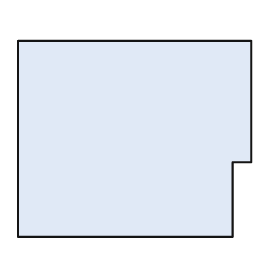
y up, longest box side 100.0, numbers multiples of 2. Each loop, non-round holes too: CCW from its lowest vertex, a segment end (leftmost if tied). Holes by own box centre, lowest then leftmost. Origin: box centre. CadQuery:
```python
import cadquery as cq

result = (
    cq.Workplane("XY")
    .moveTo(-50.0, -42.0)
    .lineTo(42.0, -42.0)
    .lineTo(42.0, -10.0)
    .lineTo(50.0, -10.0)
    .lineTo(50.0, 42.0)
    .lineTo(-50.0, 42.0)
    .close()
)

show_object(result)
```